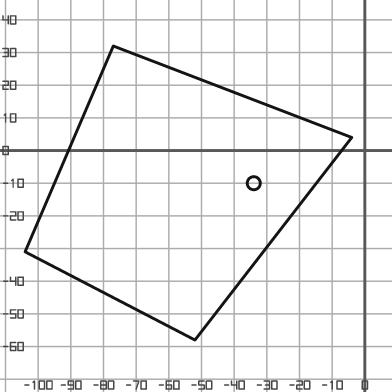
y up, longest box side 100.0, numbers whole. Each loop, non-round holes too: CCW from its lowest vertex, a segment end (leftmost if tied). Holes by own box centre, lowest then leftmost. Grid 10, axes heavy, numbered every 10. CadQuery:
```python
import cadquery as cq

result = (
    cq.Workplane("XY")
    .moveTo(-52.0, -58.0)
    .lineTo(-4.0, 4.0)
    .lineTo(-77.0, 32.0)
    .lineTo(-104.0, -31.0)
    .close()
    .moveTo(-34.0, -10.0)
    .circle(2.0)
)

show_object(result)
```